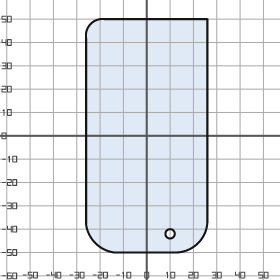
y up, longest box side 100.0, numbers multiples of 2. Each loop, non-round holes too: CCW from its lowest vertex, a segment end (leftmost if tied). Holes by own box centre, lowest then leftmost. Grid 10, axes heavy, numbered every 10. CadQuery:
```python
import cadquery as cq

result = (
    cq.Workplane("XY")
    .moveTo(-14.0, -50.0)
    .lineTo(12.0, -50.0)
    .threePointArc((22.0, -46.0), (26.0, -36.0))
    .lineTo(26.0, 50.0)
    .lineTo(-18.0, 50.0)
    .threePointArc((-24.0, 48.0), (-26.0, 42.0))
    .lineTo(-26.0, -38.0)
    .threePointArc((-22.0, -46.0), (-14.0, -50.0))
    .close()
    .moveTo(10.0, -42.0)
    .circle(2.0)
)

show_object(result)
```